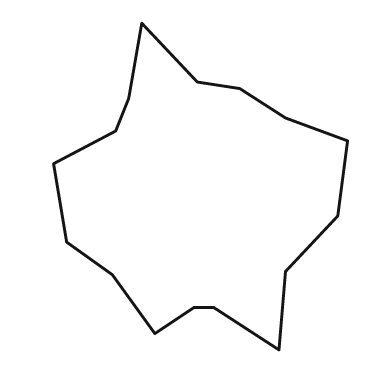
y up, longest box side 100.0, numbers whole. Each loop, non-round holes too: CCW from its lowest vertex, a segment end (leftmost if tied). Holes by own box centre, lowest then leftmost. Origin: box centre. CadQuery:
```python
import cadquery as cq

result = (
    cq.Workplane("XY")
    .moveTo(24.0, -50.0)
    .lineTo(26.0, -26.0)
    .lineTo(42.0, -9.0)
    .lineTo(45.0, 14.0)
    .lineTo(26.0, 21.0)
    .lineTo(12.0, 30.0)
    .lineTo(-1.0, 32.0)
    .lineTo(-18.0, 50.0)
    .lineTo(-22.0, 27.0)
    .lineTo(-26.0, 17.0)
    .lineTo(-45.0, 7.0)
    .lineTo(-41.0, -17.0)
    .lineTo(-27.0, -27.0)
    .lineTo(-14.0, -45.0)
    .lineTo(-2.0, -37.0)
    .lineTo(4.0, -37.0)
    .close()
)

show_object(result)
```